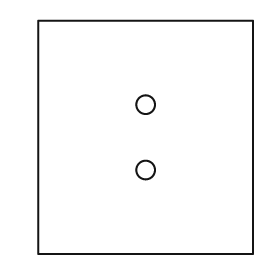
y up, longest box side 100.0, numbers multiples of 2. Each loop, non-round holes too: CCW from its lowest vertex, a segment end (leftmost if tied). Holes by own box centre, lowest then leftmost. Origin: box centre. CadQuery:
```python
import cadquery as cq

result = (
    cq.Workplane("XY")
    .moveTo(-46.0, -50.0)
    .lineTo(46.0, -50.0)
    .lineTo(46.0, 50.0)
    .lineTo(-46.0, 50.0)
    .close()
    .moveTo(0.0, -14.0)
    .circle(4.0)
    .moveTo(0.0, 14.0)
    .circle(4.0)
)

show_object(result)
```